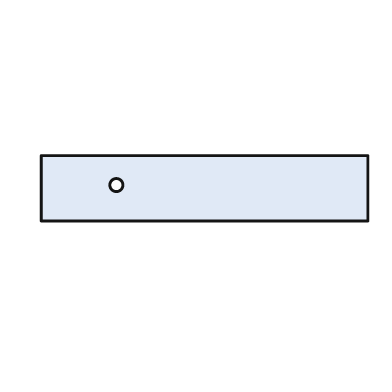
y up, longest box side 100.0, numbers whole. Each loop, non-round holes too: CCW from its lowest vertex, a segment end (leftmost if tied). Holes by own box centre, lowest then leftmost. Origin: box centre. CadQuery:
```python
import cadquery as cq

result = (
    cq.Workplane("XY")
    .moveTo(-50.0, -10.0)
    .lineTo(50.0, -10.0)
    .lineTo(50.0, 10.0)
    .lineTo(-50.0, 10.0)
    .close()
    .moveTo(-27.0, 1.0)
    .circle(2.0)
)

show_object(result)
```